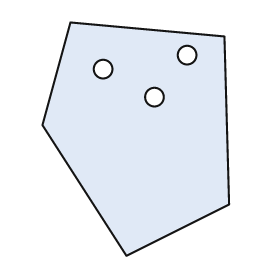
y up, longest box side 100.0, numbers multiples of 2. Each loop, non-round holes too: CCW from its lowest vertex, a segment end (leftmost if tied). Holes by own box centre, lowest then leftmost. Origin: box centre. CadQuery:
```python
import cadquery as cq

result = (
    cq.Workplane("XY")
    .moveTo(-4.0, -50.0)
    .lineTo(40.0, -28.0)
    .lineTo(38.0, 44.0)
    .lineTo(-28.0, 50.0)
    .lineTo(-40.0, 6.0)
    .close()
    .moveTo(8.0, 18.0)
    .circle(4.0)
    .moveTo(-14.0, 30.0)
    .circle(4.0)
    .moveTo(22.0, 36.0)
    .circle(4.0)
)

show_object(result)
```